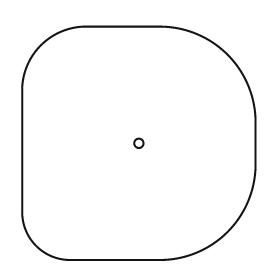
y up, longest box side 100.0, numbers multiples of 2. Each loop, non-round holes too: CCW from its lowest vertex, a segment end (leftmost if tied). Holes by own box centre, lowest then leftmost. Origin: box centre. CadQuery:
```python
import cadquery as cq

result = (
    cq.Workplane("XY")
    .moveTo(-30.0, -50.0)
    .lineTo(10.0, -50.0)
    .threePointArc((38.0, -38.0), (50.0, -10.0))
    .lineTo(50.0, 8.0)
    .threePointArc((38.0, 38.0), (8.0, 50.0))
    .lineTo(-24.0, 50.0)
    .threePointArc((-42.0, 42.0), (-50.0, 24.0))
    .lineTo(-50.0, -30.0)
    .threePointArc((-44.0, -44.0), (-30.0, -50.0))
    .close()
    .moveTo(0.0, 0.0)
    .circle(2.0)
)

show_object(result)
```